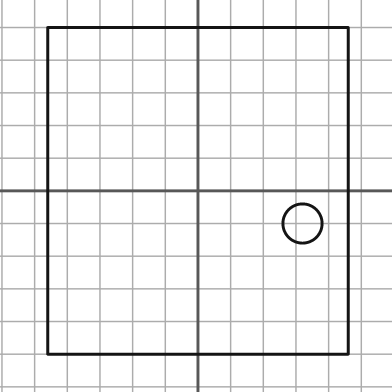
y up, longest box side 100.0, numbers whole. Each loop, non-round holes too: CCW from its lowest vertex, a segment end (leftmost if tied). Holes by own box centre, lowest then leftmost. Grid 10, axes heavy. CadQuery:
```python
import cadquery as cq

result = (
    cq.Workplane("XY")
    .moveTo(-46.0, -50.0)
    .lineTo(46.0, -50.0)
    .lineTo(46.0, 50.0)
    .lineTo(-46.0, 50.0)
    .close()
    .moveTo(32.0, -10.0)
    .circle(6.0)
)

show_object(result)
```